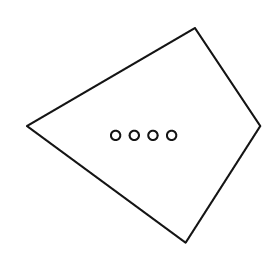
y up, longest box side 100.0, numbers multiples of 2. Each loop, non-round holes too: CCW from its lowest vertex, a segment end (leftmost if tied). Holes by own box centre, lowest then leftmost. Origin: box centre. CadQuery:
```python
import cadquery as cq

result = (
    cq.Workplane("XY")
    .moveTo(18.0, -46.0)
    .lineTo(50.0, 4.0)
    .lineTo(22.0, 46.0)
    .lineTo(-50.0, 4.0)
    .close()
    .moveTo(-12.0, 0.0)
    .circle(2.0)
    .moveTo(-4.0, 0.0)
    .circle(2.0)
    .moveTo(4.0, 0.0)
    .circle(2.0)
    .moveTo(12.0, 0.0)
    .circle(2.0)
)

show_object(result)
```